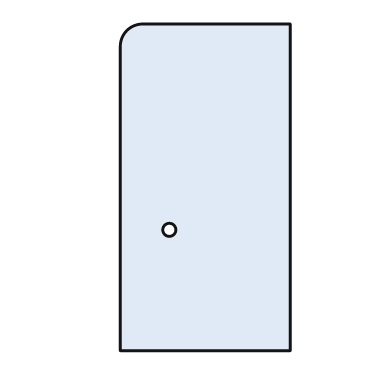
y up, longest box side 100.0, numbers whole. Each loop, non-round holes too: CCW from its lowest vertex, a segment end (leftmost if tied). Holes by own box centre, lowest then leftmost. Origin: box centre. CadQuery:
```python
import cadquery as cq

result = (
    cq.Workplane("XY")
    .moveTo(-26.0, -50.0)
    .lineTo(26.0, -50.0)
    .lineTo(26.0, 50.0)
    .lineTo(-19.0, 50.0)
    .threePointArc((-24.0, 48.0), (-26.0, 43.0))
    .close()
    .moveTo(-11.0, -13.0)
    .circle(2.0)
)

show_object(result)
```